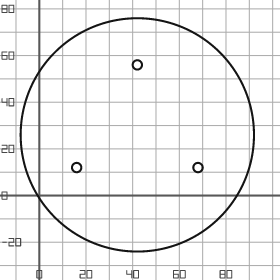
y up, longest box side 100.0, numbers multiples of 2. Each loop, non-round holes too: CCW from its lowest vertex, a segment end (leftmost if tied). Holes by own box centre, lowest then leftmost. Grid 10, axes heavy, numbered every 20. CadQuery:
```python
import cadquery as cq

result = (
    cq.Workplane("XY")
    .moveTo(42.0, 26.0)
    .circle(50.0)
    .moveTo(16.0, 12.0)
    .circle(2.0)
    .moveTo(68.0, 12.0)
    .circle(2.0)
    .moveTo(42.0, 56.0)
    .circle(2.0)
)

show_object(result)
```